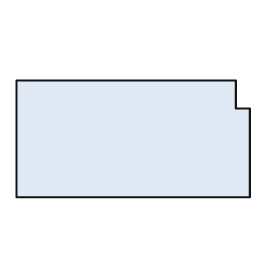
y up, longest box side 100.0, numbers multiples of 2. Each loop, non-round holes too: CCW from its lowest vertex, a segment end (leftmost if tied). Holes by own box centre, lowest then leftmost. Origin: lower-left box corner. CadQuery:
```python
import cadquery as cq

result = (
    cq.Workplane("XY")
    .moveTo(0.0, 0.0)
    .lineTo(100.0, 0.0)
    .lineTo(100.0, 38.0)
    .lineTo(94.0, 38.0)
    .lineTo(94.0, 50.0)
    .lineTo(0.0, 50.0)
    .close()
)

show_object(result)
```